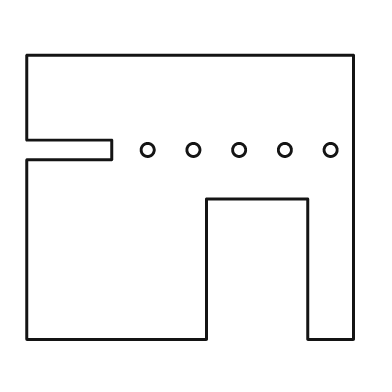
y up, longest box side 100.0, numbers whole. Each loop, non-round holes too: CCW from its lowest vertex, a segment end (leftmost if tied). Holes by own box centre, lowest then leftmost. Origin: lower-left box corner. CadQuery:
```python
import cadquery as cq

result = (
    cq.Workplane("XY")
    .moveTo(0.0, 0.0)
    .lineTo(55.0, 0.0)
    .lineTo(55.0, 43.0)
    .lineTo(86.0, 43.0)
    .lineTo(86.0, 0.0)
    .lineTo(100.0, 0.0)
    .lineTo(100.0, 87.0)
    .lineTo(0.0, 87.0)
    .lineTo(0.0, 61.0)
    .lineTo(26.0, 61.0)
    .lineTo(26.0, 55.0)
    .lineTo(0.0, 55.0)
    .close()
    .moveTo(37.0, 58.0)
    .circle(2.0)
    .moveTo(51.0, 58.0)
    .circle(2.0)
    .moveTo(65.0, 58.0)
    .circle(2.0)
    .moveTo(79.0, 58.0)
    .circle(2.0)
    .moveTo(93.0, 58.0)
    .circle(2.0)
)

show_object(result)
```